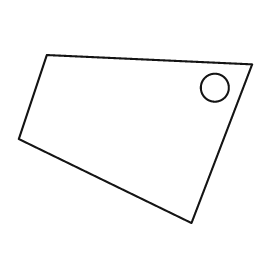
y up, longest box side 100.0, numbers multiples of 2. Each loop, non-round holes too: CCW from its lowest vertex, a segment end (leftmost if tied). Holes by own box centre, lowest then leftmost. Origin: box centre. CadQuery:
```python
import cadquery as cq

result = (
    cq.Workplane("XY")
    .moveTo(24.0, -36.0)
    .lineTo(50.0, 32.0)
    .lineTo(-38.0, 36.0)
    .lineTo(-50.0, 0.0)
    .close()
    .moveTo(34.0, 22.0)
    .circle(6.0)
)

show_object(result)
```